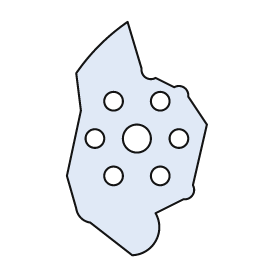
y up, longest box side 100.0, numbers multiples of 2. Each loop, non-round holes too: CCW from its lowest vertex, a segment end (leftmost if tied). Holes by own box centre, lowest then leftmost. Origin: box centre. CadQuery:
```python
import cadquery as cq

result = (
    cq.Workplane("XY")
    .moveTo(-2.0, -50.0)
    .threePointArc((8.0, -44.0), (8.0, -32.0))
    .lineTo(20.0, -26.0)
    .threePointArc((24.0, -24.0), (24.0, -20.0))
    .lineTo(30.0, 6.0)
    .lineTo(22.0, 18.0)
    .threePointArc((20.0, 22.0), (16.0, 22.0))
    .lineTo(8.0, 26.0)
    .threePointArc((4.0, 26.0), (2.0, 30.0))
    .lineTo(-4.0, 50.0)
    .threePointArc((-16.0, 40.0), (-26.0, 28.0))
    .lineTo(-24.0, 12.0)
    .lineTo(-30.0, -16.0)
    .lineTo(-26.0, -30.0)
    .threePointArc((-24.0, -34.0), (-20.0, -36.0))
    .close()
    .moveTo(-10.0, -16.0)
    .circle(4.0)
    .moveTo(10.0, -16.0)
    .circle(4.0)
    .moveTo(-18.0, 0.0)
    .circle(4.0)
    .moveTo(0.0, 0.0)
    .circle(6.0)
    .moveTo(18.0, 0.0)
    .circle(4.0)
    .moveTo(-10.0, 16.0)
    .circle(4.0)
    .moveTo(10.0, 16.0)
    .circle(4.0)
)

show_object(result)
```